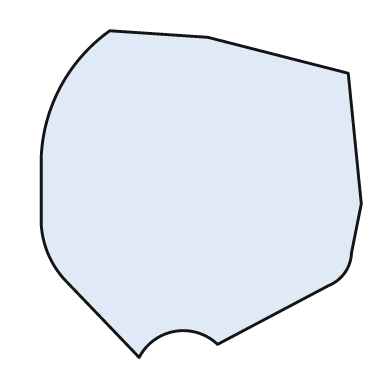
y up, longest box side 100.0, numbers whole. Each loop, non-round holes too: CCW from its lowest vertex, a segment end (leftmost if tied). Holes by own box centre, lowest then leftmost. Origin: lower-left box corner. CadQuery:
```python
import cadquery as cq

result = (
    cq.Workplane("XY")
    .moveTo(30.0, 0.0)
    .threePointArc((41.0, 8.0), (54.0, 4.0))
    .lineTo(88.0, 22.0)
    .threePointArc((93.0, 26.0), (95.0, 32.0))
    .lineTo(98.0, 47.0)
    .lineTo(94.0, 87.0)
    .lineTo(51.0, 98.0)
    .lineTo(21.0, 100.0)
    .threePointArc((6.0, 83.0), (0.0, 61.0))
    .lineTo(0.0, 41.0)
    .threePointArc((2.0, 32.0), (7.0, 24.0))
    .close()
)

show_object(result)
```